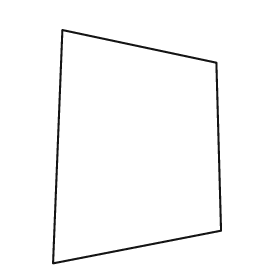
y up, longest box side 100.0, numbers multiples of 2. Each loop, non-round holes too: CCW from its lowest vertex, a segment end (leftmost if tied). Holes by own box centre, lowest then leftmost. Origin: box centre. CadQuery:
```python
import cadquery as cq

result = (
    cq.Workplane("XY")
    .moveTo(-36.0, -50.0)
    .lineTo(36.0, -36.0)
    .lineTo(34.0, 36.0)
    .lineTo(-32.0, 50.0)
    .close()
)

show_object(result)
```